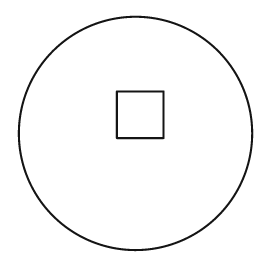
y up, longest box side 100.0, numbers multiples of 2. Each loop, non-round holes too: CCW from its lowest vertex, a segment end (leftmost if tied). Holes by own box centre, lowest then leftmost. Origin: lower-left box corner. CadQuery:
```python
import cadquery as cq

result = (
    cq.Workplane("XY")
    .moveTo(50.0, 50.0)
    .circle(50.0)
    .moveTo(42.0, 48.0)
    .lineTo(62.0, 48.0)
    .lineTo(62.0, 68.0)
    .lineTo(42.0, 68.0)
    .close()
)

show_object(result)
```